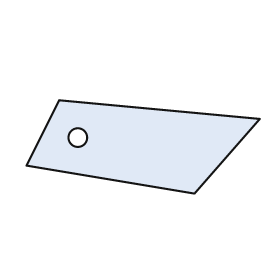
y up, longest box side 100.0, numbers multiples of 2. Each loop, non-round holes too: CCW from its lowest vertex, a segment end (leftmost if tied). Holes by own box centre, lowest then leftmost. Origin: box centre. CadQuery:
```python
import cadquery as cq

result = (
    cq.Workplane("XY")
    .moveTo(22.0, -20.0)
    .lineTo(50.0, 12.0)
    .lineTo(-36.0, 20.0)
    .lineTo(-50.0, -8.0)
    .close()
    .moveTo(-28.0, 4.0)
    .circle(4.0)
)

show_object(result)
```